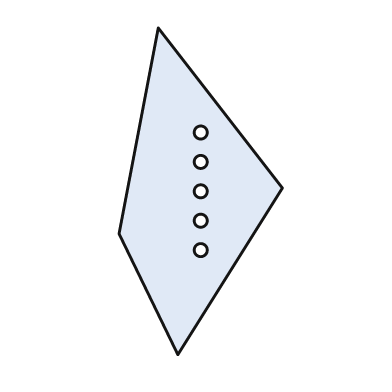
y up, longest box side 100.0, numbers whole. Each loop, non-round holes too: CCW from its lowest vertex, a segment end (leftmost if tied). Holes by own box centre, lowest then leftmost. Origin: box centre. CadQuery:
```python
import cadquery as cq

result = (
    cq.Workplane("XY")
    .moveTo(-7.0, -50.0)
    .lineTo(25.0, 1.0)
    .lineTo(-13.0, 50.0)
    .lineTo(-25.0, -13.0)
    .close()
    .moveTo(0.0, -18.0)
    .circle(2.0)
    .moveTo(0.0, -9.0)
    .circle(2.0)
    .moveTo(0.0, 0.0)
    .circle(2.0)
    .moveTo(0.0, 9.0)
    .circle(2.0)
    .moveTo(0.0, 18.0)
    .circle(2.0)
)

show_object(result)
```